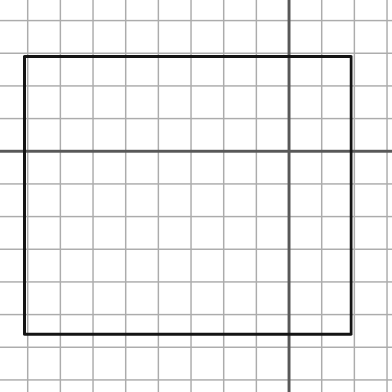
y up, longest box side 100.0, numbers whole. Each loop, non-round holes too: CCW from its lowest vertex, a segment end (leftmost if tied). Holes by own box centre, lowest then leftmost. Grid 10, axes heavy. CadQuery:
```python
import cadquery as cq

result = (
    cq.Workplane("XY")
    .moveTo(-81.0, -56.0)
    .lineTo(19.0, -56.0)
    .lineTo(19.0, 29.0)
    .lineTo(-81.0, 29.0)
    .close()
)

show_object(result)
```